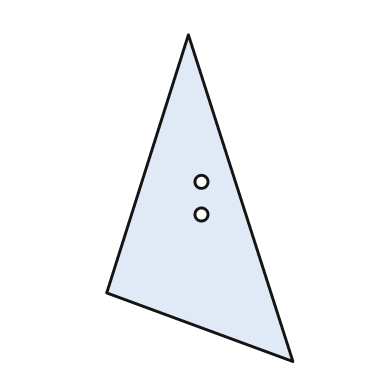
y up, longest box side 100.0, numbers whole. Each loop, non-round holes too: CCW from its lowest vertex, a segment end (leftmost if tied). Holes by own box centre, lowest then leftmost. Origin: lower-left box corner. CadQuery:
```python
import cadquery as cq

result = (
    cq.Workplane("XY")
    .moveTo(57.0, 0.0)
    .lineTo(25.0, 100.0)
    .lineTo(0.0, 21.0)
    .close()
    .moveTo(29.0, 45.0)
    .circle(2.0)
    .moveTo(29.0, 55.0)
    .circle(2.0)
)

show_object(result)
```